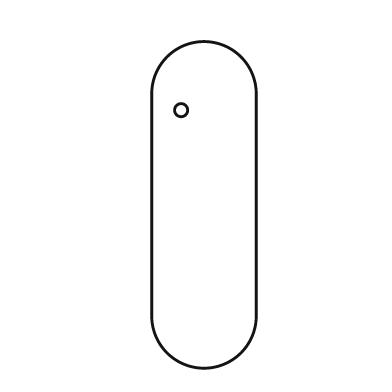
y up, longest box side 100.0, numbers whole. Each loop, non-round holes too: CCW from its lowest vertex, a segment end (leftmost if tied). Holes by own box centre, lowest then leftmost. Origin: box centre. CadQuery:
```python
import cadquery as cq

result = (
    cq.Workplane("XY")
    .moveTo(-16.0, -34.0)
    .threePointArc((0.0, -50.0), (16.0, -34.0))
    .lineTo(16.0, 34.0)
    .threePointArc((0.0, 50.0), (-16.0, 34.0))
    .close()
    .moveTo(-7.0, 29.0)
    .circle(2.0)
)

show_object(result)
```